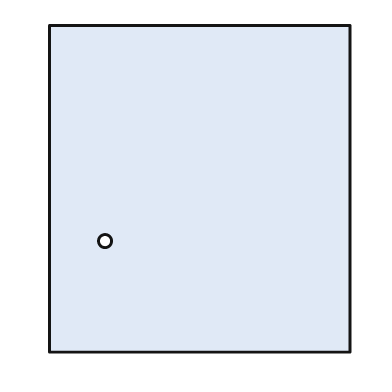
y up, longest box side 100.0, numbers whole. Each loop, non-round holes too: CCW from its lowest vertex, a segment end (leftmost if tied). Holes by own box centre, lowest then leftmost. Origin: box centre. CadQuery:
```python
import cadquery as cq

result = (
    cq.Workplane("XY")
    .moveTo(-46.0, -50.0)
    .lineTo(46.0, -50.0)
    .lineTo(46.0, 50.0)
    .lineTo(-46.0, 50.0)
    .close()
    .moveTo(-29.0, -16.0)
    .circle(2.0)
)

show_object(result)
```